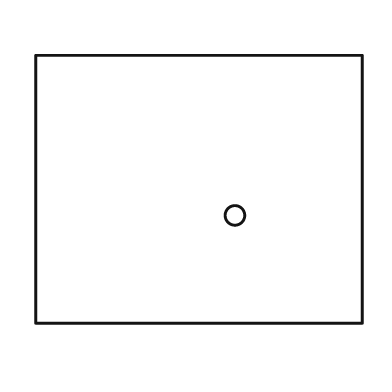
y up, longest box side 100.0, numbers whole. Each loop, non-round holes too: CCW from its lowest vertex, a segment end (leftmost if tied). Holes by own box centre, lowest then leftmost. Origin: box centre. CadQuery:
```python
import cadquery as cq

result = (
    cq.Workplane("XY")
    .moveTo(-50.0, -41.0)
    .lineTo(50.0, -41.0)
    .lineTo(50.0, 41.0)
    .lineTo(-50.0, 41.0)
    .close()
    .moveTo(11.0, -8.0)
    .circle(3.0)
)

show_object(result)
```